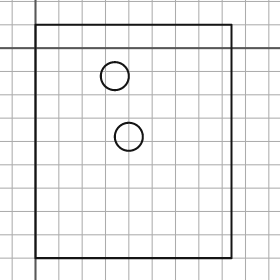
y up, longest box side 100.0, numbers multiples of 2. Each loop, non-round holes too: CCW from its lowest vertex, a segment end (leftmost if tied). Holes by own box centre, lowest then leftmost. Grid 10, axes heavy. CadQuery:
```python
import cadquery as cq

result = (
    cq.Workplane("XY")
    .moveTo(0.0, -90.0)
    .lineTo(84.0, -90.0)
    .lineTo(84.0, 10.0)
    .lineTo(0.0, 10.0)
    .close()
    .moveTo(40.0, -38.0)
    .circle(6.0)
    .moveTo(34.0, -12.0)
    .circle(6.0)
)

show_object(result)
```